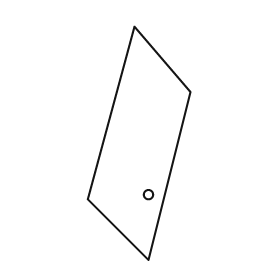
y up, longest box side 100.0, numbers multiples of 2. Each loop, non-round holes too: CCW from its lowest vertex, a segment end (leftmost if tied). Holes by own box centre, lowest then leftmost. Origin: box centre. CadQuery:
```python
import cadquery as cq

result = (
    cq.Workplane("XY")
    .moveTo(4.0, -50.0)
    .lineTo(22.0, 22.0)
    .lineTo(-2.0, 50.0)
    .lineTo(-22.0, -24.0)
    .close()
    .moveTo(4.0, -22.0)
    .circle(2.0)
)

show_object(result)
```